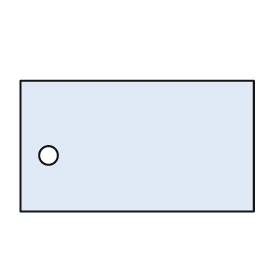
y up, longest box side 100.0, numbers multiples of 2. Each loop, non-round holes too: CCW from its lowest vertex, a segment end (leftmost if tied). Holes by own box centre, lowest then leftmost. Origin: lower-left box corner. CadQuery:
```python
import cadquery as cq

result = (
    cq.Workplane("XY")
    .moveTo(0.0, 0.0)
    .lineTo(100.0, 0.0)
    .lineTo(100.0, 56.0)
    .lineTo(0.0, 56.0)
    .close()
    .moveTo(12.0, 24.0)
    .circle(4.0)
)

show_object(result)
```